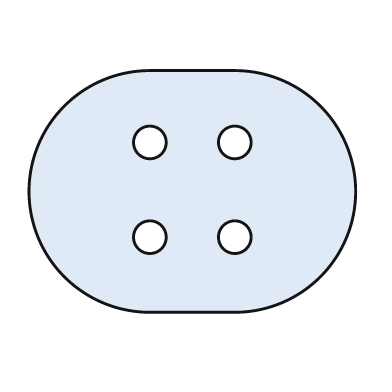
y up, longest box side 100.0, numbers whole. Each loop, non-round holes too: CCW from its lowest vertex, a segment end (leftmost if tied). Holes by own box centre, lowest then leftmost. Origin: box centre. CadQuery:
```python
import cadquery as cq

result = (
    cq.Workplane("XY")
    .moveTo(-13.0, -37.0)
    .lineTo(13.0, -37.0)
    .threePointArc((50.0, 0.0), (13.0, 37.0))
    .lineTo(-13.0, 37.0)
    .threePointArc((-50.0, 0.0), (-13.0, -37.0))
    .close()
    .moveTo(-13.0, -14.0)
    .circle(5.0)
    .moveTo(13.0, -14.0)
    .circle(5.0)
    .moveTo(-13.0, 15.0)
    .circle(5.0)
    .moveTo(13.0, 15.0)
    .circle(5.0)
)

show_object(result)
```